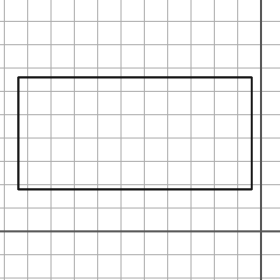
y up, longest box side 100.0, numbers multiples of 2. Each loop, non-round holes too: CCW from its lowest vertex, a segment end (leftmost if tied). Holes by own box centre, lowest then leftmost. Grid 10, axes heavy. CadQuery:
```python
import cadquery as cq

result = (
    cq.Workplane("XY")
    .moveTo(-104.0, 18.0)
    .lineTo(-4.0, 18.0)
    .lineTo(-4.0, 66.0)
    .lineTo(-104.0, 66.0)
    .close()
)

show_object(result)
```